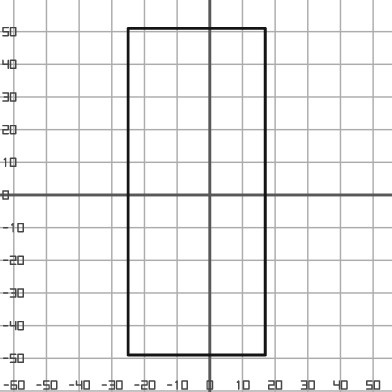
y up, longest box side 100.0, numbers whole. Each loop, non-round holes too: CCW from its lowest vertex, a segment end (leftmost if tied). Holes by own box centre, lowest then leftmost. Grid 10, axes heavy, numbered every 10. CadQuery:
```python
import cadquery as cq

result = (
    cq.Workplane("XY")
    .moveTo(-25.0, -49.0)
    .lineTo(17.0, -49.0)
    .lineTo(17.0, 51.0)
    .lineTo(-25.0, 51.0)
    .close()
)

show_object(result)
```